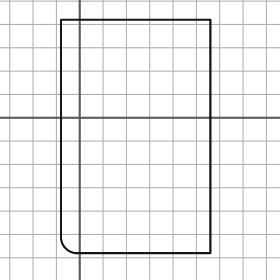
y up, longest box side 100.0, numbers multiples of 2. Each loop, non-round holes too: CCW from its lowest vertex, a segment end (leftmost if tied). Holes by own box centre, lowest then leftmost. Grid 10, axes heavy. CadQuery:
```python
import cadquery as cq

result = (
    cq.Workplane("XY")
    .moveTo(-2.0, -58.0)
    .lineTo(56.0, -58.0)
    .lineTo(56.0, 42.0)
    .lineTo(-8.0, 42.0)
    .lineTo(-8.0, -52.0)
    .threePointArc((-6.0, -56.0), (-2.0, -58.0))
    .close()
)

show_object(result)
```